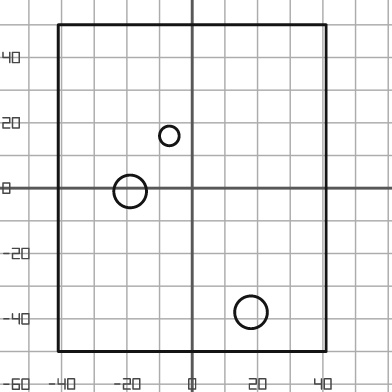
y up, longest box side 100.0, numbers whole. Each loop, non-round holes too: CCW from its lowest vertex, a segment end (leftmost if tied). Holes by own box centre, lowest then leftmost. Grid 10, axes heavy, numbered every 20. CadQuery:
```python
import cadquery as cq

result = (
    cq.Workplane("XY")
    .moveTo(-41.0, -50.0)
    .lineTo(41.0, -50.0)
    .lineTo(41.0, 50.0)
    .lineTo(-41.0, 50.0)
    .close()
    .moveTo(18.0, -38.0)
    .circle(5.0)
    .moveTo(-19.0, -1.0)
    .circle(5.0)
    .moveTo(-7.0, 16.0)
    .circle(3.0)
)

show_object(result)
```